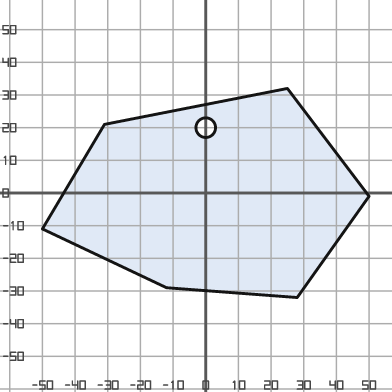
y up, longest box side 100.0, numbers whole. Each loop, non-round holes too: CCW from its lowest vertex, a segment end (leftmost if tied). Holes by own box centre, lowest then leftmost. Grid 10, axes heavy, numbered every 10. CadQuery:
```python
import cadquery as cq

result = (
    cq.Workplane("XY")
    .moveTo(28.0, -32.0)
    .lineTo(50.0, -1.0)
    .lineTo(25.0, 32.0)
    .lineTo(-31.0, 21.0)
    .lineTo(-50.0, -11.0)
    .lineTo(-12.0, -29.0)
    .close()
    .moveTo(0.0, 20.0)
    .circle(3.0)
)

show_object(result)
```